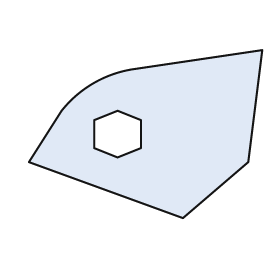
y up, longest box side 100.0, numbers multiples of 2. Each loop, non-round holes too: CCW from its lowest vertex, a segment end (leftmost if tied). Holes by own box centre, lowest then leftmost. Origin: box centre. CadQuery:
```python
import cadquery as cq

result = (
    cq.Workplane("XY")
    .moveTo(16.0, -36.0)
    .lineTo(44.0, -12.0)
    .lineTo(50.0, 36.0)
    .lineTo(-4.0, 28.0)
    .threePointArc((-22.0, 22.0), (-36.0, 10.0))
    .lineTo(-50.0, -12.0)
    .close()
    .moveTo(-12.0, -10.0)
    .lineTo(-2.0, -6.0)
    .lineTo(-2.0, 6.0)
    .lineTo(-12.0, 10.0)
    .lineTo(-22.0, 6.0)
    .lineTo(-22.0, -6.0)
    .close()
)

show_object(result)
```